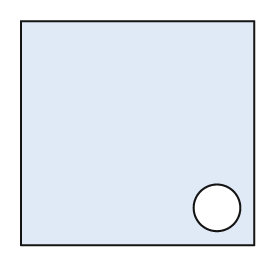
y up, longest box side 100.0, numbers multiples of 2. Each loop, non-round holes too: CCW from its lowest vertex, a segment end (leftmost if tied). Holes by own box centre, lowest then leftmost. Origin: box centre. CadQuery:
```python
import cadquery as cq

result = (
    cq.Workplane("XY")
    .moveTo(-50.0, -48.0)
    .lineTo(50.0, -48.0)
    .lineTo(50.0, 48.0)
    .lineTo(-50.0, 48.0)
    .close()
    .moveTo(34.0, -32.0)
    .circle(10.0)
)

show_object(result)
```